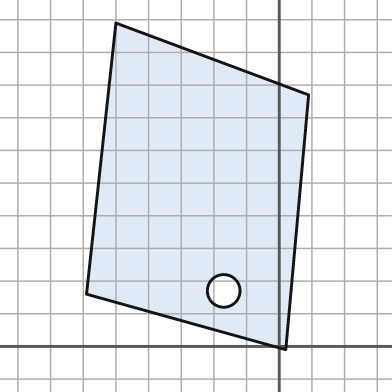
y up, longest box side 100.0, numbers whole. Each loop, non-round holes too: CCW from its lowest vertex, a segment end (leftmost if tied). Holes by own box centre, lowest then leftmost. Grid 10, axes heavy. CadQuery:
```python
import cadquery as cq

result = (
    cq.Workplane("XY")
    .moveTo(2.0, -1.0)
    .lineTo(9.0, 77.0)
    .lineTo(-50.0, 99.0)
    .lineTo(-59.0, 16.0)
    .close()
    .moveTo(-17.0, 17.0)
    .circle(5.0)
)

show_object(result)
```